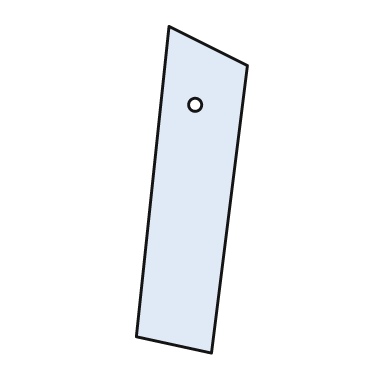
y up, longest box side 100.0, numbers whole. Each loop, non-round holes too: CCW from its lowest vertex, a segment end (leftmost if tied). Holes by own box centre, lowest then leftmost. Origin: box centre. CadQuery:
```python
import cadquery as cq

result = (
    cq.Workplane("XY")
    .moveTo(6.0, -50.0)
    .lineTo(17.0, 38.0)
    .lineTo(-7.0, 50.0)
    .lineTo(-17.0, -45.0)
    .close()
    .moveTo(1.0, 26.0)
    .circle(2.0)
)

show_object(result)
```